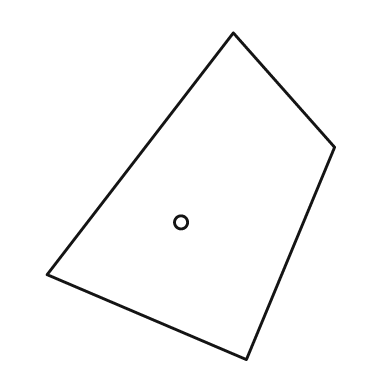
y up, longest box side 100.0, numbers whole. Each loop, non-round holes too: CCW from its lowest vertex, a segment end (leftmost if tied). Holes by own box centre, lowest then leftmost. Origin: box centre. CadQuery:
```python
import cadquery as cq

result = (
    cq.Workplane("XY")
    .moveTo(17.0, -50.0)
    .lineTo(44.0, 15.0)
    .lineTo(13.0, 50.0)
    .lineTo(-44.0, -24.0)
    .close()
    .moveTo(-3.0, -8.0)
    .circle(2.0)
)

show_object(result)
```